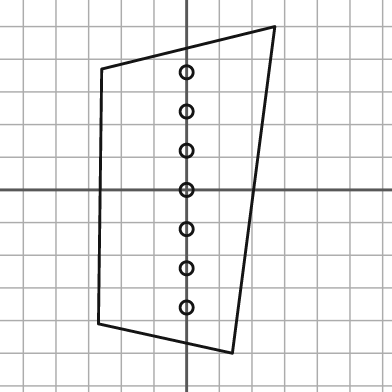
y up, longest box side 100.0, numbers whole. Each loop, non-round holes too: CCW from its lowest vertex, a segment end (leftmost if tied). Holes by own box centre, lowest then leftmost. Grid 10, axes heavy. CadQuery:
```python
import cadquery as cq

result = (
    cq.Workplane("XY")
    .moveTo(14.0, -50.0)
    .lineTo(27.0, 50.0)
    .lineTo(-26.0, 37.0)
    .lineTo(-27.0, -41.0)
    .close()
    .moveTo(0.0, -36.0)
    .circle(2.0)
    .moveTo(0.0, -24.0)
    .circle(2.0)
    .moveTo(0.0, -12.0)
    .circle(2.0)
    .moveTo(0.0, 0.0)
    .circle(2.0)
    .moveTo(0.0, 12.0)
    .circle(2.0)
    .moveTo(0.0, 24.0)
    .circle(2.0)
    .moveTo(0.0, 36.0)
    .circle(2.0)
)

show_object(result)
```